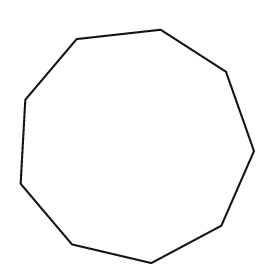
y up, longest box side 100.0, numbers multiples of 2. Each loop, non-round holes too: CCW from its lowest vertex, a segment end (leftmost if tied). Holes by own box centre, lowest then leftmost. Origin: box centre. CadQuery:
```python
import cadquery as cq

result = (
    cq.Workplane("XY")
    .moveTo(6.0, -50.0)
    .lineTo(36.0, -34.0)
    .lineTo(50.0, -2.0)
    .lineTo(38.0, 32.0)
    .lineTo(10.0, 50.0)
    .lineTo(-26.0, 46.0)
    .lineTo(-48.0, 20.0)
    .lineTo(-50.0, -16.0)
    .lineTo(-28.0, -42.0)
    .close()
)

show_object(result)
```